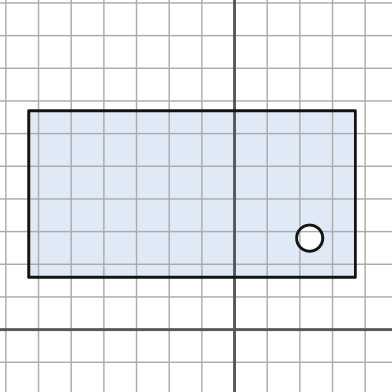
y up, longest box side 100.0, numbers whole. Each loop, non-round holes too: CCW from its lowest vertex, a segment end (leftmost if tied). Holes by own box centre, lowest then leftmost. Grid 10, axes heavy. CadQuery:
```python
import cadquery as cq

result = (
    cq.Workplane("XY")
    .moveTo(-63.0, 16.0)
    .lineTo(37.0, 16.0)
    .lineTo(37.0, 67.0)
    .lineTo(-63.0, 67.0)
    .close()
    .moveTo(23.0, 28.0)
    .circle(4.0)
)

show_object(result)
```